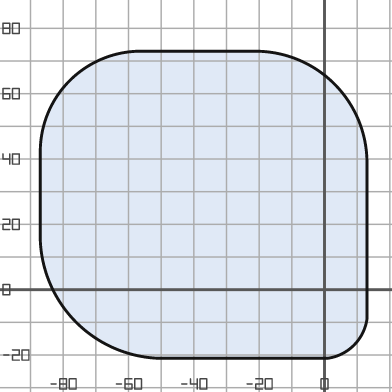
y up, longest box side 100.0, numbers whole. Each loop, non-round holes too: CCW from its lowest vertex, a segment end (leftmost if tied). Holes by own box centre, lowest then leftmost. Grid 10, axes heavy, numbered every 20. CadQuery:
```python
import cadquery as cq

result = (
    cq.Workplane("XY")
    .moveTo(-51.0, -21.0)
    .lineTo(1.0, -21.0)
    .threePointArc((9.0, -17.0), (13.0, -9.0))
    .lineTo(13.0, 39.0)
    .threePointArc((3.0, 63.0), (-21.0, 73.0))
    .lineTo(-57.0, 73.0)
    .threePointArc((-78.0, 64.0), (-87.0, 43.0))
    .lineTo(-87.0, 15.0)
    .threePointArc((-76.0, -10.0), (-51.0, -21.0))
    .close()
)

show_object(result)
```